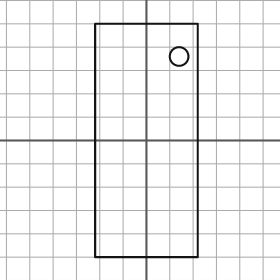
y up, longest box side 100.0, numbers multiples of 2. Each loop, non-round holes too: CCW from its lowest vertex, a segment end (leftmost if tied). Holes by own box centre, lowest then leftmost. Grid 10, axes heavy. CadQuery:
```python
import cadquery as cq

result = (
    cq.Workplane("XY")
    .moveTo(-22.0, -50.0)
    .lineTo(22.0, -50.0)
    .lineTo(22.0, 50.0)
    .lineTo(-22.0, 50.0)
    .close()
    .moveTo(14.0, 36.0)
    .circle(4.0)
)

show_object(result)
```